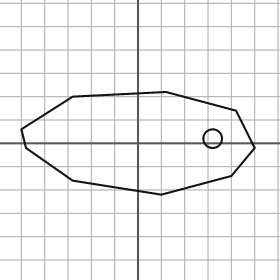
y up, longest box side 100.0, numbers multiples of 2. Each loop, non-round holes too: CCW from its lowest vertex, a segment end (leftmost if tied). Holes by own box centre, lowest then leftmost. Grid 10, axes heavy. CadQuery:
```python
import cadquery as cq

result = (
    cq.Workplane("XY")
    .moveTo(10.0, -22.0)
    .lineTo(40.0, -14.0)
    .lineTo(50.0, -2.0)
    .lineTo(42.0, 14.0)
    .lineTo(12.0, 22.0)
    .lineTo(-28.0, 20.0)
    .lineTo(-50.0, 6.0)
    .lineTo(-48.0, -2.0)
    .lineTo(-28.0, -16.0)
    .close()
    .moveTo(32.0, 2.0)
    .circle(4.0)
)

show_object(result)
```